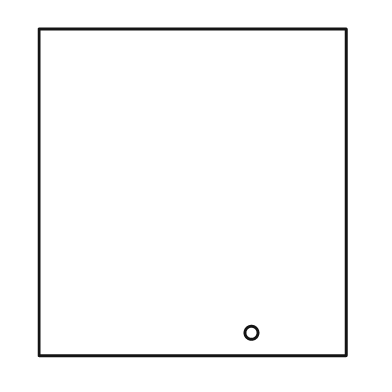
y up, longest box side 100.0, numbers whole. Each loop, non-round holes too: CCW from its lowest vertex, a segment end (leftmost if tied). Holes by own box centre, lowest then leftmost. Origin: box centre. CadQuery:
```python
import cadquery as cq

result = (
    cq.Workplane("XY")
    .moveTo(-47.0, -50.0)
    .lineTo(47.0, -50.0)
    .lineTo(47.0, 50.0)
    .lineTo(-47.0, 50.0)
    .close()
    .moveTo(18.0, -43.0)
    .circle(2.0)
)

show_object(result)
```